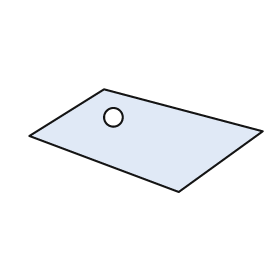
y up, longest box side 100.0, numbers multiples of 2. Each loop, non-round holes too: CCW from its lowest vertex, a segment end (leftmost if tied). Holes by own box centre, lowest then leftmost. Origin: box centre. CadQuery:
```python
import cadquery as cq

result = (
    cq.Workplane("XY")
    .moveTo(14.0, -22.0)
    .lineTo(50.0, 4.0)
    .lineTo(-18.0, 22.0)
    .lineTo(-50.0, 2.0)
    .close()
    .moveTo(-14.0, 10.0)
    .circle(4.0)
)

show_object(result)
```